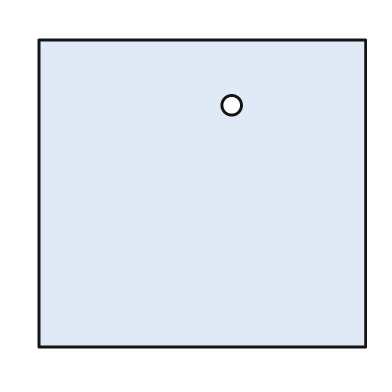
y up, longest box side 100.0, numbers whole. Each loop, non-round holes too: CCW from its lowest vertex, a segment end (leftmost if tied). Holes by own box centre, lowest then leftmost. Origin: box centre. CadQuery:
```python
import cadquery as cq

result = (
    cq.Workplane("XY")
    .moveTo(-50.0, -47.0)
    .lineTo(50.0, -47.0)
    .lineTo(50.0, 47.0)
    .lineTo(-50.0, 47.0)
    .close()
    .moveTo(9.0, 27.0)
    .circle(3.0)
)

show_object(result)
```